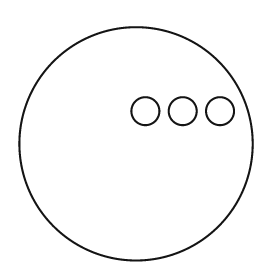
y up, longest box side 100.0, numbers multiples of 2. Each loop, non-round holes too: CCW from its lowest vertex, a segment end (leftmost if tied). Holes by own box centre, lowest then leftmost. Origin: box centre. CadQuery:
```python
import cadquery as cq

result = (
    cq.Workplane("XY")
    .moveTo(0.0, 0.0)
    .circle(50.0)
    .moveTo(4.0, 14.0)
    .circle(6.0)
    .moveTo(20.0, 14.0)
    .circle(6.0)
    .moveTo(36.0, 14.0)
    .circle(6.0)
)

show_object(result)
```